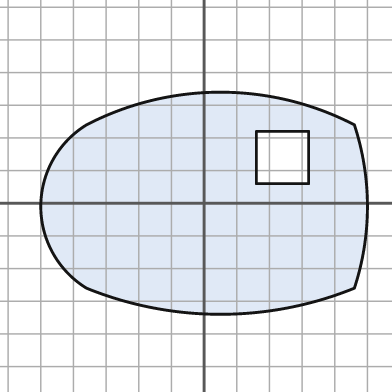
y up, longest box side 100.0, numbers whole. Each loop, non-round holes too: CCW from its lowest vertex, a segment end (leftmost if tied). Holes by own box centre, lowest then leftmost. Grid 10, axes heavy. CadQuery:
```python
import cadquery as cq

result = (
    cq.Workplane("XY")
    .moveTo(-36.0, -26.0)
    .threePointArc((5.0, -34.0), (46.0, -26.0))
    .threePointArc((50.0, -1.0), (46.0, 24.0))
    .threePointArc((5.0, 34.0), (-36.0, 24.0))
    .threePointArc((-50.0, -1.0), (-36.0, -26.0))
    .close()
    .moveTo(16.0, 6.0)
    .lineTo(32.0, 6.0)
    .lineTo(32.0, 22.0)
    .lineTo(16.0, 22.0)
    .close()
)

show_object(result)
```